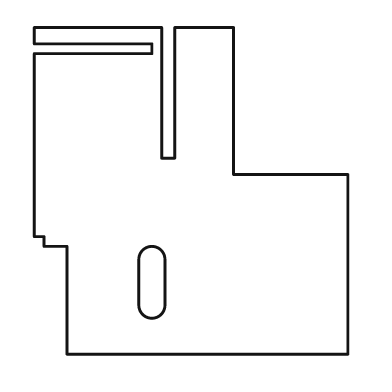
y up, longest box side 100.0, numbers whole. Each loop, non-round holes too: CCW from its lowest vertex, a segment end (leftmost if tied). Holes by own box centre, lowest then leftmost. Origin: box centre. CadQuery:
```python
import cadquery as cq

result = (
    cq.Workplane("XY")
    .moveTo(-38.0, -50.0)
    .lineTo(48.0, -50.0)
    .lineTo(48.0, 5.0)
    .lineTo(13.0, 5.0)
    .lineTo(13.0, 50.0)
    .lineTo(-5.0, 50.0)
    .lineTo(-5.0, 10.0)
    .lineTo(-9.0, 10.0)
    .lineTo(-9.0, 50.0)
    .lineTo(-48.0, 50.0)
    .lineTo(-48.0, 45.0)
    .lineTo(-12.0, 45.0)
    .lineTo(-12.0, 42.0)
    .lineTo(-48.0, 42.0)
    .lineTo(-48.0, -14.0)
    .lineTo(-45.0, -14.0)
    .lineTo(-45.0, -17.0)
    .lineTo(-38.0, -17.0)
    .close()
    .moveTo(-16.0, -35.0)
    .threePointArc((-12.0, -39.0), (-8.0, -35.0))
    .lineTo(-8.0, -21.0)
    .threePointArc((-12.0, -17.0), (-16.0, -21.0))
    .close()
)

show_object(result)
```